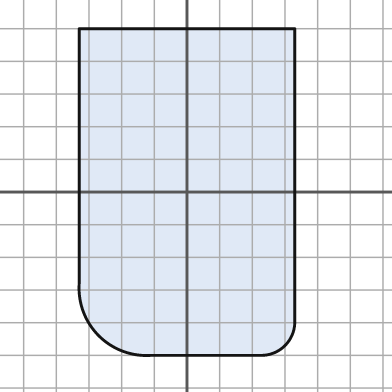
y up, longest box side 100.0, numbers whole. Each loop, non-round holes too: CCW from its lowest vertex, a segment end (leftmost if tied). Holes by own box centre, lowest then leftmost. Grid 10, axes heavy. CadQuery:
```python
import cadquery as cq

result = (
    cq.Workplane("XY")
    .moveTo(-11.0, -50.0)
    .lineTo(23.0, -50.0)
    .threePointArc((30.0, -47.0), (33.0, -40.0))
    .lineTo(33.0, 50.0)
    .lineTo(-33.0, 50.0)
    .lineTo(-33.0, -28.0)
    .threePointArc((-27.0, -44.0), (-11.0, -50.0))
    .close()
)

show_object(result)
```